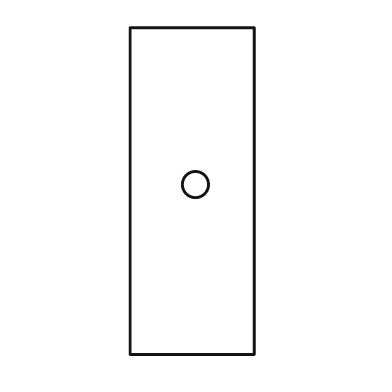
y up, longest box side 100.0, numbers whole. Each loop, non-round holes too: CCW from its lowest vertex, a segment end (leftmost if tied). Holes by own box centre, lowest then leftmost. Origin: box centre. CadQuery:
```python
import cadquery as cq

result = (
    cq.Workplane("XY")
    .moveTo(-19.0, -50.0)
    .lineTo(19.0, -50.0)
    .lineTo(19.0, 50.0)
    .lineTo(-19.0, 50.0)
    .close()
    .moveTo(1.0, 2.0)
    .circle(4.0)
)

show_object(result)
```